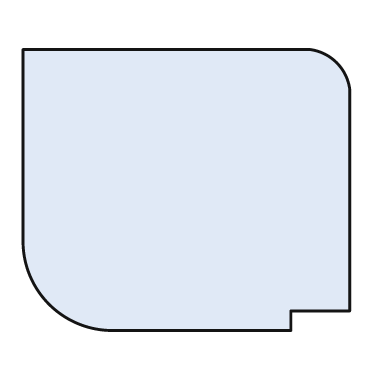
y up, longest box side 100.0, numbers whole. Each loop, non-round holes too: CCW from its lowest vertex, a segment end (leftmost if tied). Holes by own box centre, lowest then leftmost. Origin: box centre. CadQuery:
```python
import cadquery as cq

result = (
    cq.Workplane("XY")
    .moveTo(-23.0, -43.0)
    .lineTo(32.0, -43.0)
    .lineTo(32.0, -37.0)
    .lineTo(50.0, -37.0)
    .lineTo(50.0, 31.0)
    .threePointArc((46.0, 39.0), (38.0, 43.0))
    .lineTo(-50.0, 43.0)
    .lineTo(-50.0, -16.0)
    .threePointArc((-42.0, -35.0), (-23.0, -43.0))
    .close()
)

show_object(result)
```